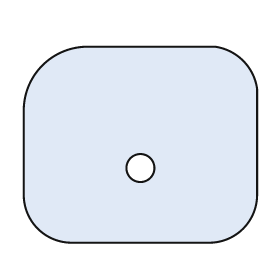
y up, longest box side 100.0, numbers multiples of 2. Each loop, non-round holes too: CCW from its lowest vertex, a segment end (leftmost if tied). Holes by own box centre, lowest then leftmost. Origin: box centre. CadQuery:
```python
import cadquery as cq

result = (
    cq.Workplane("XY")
    .moveTo(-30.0, -42.0)
    .lineTo(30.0, -42.0)
    .threePointArc((44.0, -36.0), (50.0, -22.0))
    .lineTo(50.0, 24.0)
    .threePointArc((44.0, 36.0), (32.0, 42.0))
    .lineTo(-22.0, 42.0)
    .threePointArc((-42.0, 34.0), (-50.0, 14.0))
    .lineTo(-50.0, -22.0)
    .threePointArc((-44.0, -36.0), (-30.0, -42.0))
    .close()
    .moveTo(0.0, -10.0)
    .circle(6.0)
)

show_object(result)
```